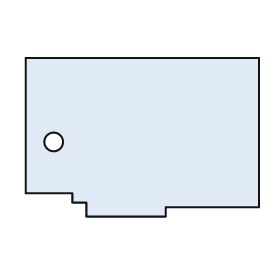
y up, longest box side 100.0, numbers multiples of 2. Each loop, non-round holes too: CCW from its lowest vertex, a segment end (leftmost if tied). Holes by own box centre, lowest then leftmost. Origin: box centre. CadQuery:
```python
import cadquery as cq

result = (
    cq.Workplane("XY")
    .moveTo(-24.0, -34.0)
    .lineTo(10.0, -34.0)
    .lineTo(10.0, -30.0)
    .lineTo(50.0, -30.0)
    .lineTo(50.0, 34.0)
    .lineTo(-50.0, 34.0)
    .lineTo(-50.0, -24.0)
    .lineTo(-30.0, -24.0)
    .lineTo(-30.0, -28.0)
    .lineTo(-24.0, -28.0)
    .close()
    .moveTo(-38.0, -2.0)
    .circle(4.0)
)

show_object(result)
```